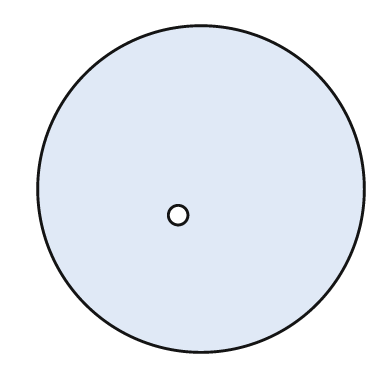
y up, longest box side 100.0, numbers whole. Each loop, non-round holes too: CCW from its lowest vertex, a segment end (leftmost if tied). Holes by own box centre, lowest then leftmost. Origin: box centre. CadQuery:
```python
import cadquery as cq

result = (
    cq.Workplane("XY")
    .moveTo(0.0, 0.0)
    .circle(50.0)
    .moveTo(-7.0, -8.0)
    .circle(3.0)
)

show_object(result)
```